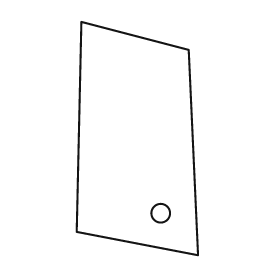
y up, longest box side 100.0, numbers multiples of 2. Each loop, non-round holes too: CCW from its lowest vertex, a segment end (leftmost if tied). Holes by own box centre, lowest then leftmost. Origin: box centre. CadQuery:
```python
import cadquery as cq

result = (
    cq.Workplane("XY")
    .moveTo(26.0, -50.0)
    .lineTo(22.0, 38.0)
    .lineTo(-24.0, 50.0)
    .lineTo(-26.0, -40.0)
    .close()
    .moveTo(10.0, -32.0)
    .circle(4.0)
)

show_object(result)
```